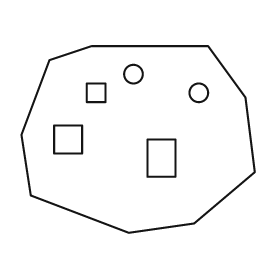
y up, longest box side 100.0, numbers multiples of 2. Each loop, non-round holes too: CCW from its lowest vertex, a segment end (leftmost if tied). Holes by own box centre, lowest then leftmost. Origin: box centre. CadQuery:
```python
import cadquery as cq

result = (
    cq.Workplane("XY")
    .moveTo(-4.0, -40.0)
    .lineTo(24.0, -36.0)
    .lineTo(50.0, -14.0)
    .lineTo(46.0, 18.0)
    .lineTo(30.0, 40.0)
    .lineTo(-20.0, 40.0)
    .lineTo(-38.0, 34.0)
    .lineTo(-50.0, 2.0)
    .lineTo(-46.0, -24.0)
    .close()
    .moveTo(4.0, -16.0)
    .lineTo(16.0, -16.0)
    .lineTo(16.0, 0.0)
    .lineTo(4.0, 0.0)
    .close()
    .moveTo(-36.0, -6.0)
    .lineTo(-24.0, -6.0)
    .lineTo(-24.0, 6.0)
    .lineTo(-36.0, 6.0)
    .close()
    .moveTo(-22.0, 16.0)
    .lineTo(-14.0, 16.0)
    .lineTo(-14.0, 24.0)
    .lineTo(-22.0, 24.0)
    .close()
    .moveTo(26.0, 20.0)
    .circle(4.0)
    .moveTo(-2.0, 28.0)
    .circle(4.0)
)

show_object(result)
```